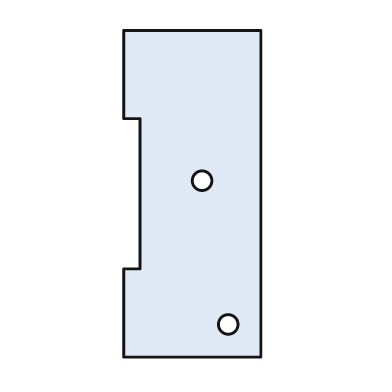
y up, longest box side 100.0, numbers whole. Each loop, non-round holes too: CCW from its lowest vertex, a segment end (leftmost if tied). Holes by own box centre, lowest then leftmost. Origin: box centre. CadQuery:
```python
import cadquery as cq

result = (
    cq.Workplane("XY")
    .moveTo(-21.0, -50.0)
    .lineTo(21.0, -50.0)
    .lineTo(21.0, 50.0)
    .lineTo(-21.0, 50.0)
    .lineTo(-21.0, 23.0)
    .lineTo(-16.0, 23.0)
    .lineTo(-16.0, -23.0)
    .lineTo(-21.0, -23.0)
    .close()
    .moveTo(11.0, -40.0)
    .circle(3.0)
    .moveTo(3.0, 4.0)
    .circle(3.0)
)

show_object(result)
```